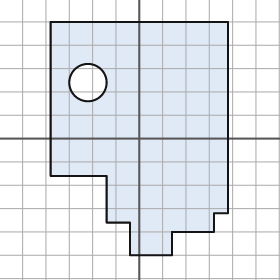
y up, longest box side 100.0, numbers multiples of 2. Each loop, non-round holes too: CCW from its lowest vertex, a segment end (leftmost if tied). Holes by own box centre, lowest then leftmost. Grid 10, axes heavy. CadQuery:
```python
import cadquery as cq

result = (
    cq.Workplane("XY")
    .moveTo(-4.0, -50.0)
    .lineTo(14.0, -50.0)
    .lineTo(14.0, -40.0)
    .lineTo(32.0, -40.0)
    .lineTo(32.0, -32.0)
    .lineTo(38.0, -32.0)
    .lineTo(38.0, 50.0)
    .lineTo(-38.0, 50.0)
    .lineTo(-38.0, -16.0)
    .lineTo(-14.0, -16.0)
    .lineTo(-14.0, -36.0)
    .lineTo(-4.0, -36.0)
    .close()
    .moveTo(-22.0, 24.0)
    .circle(8.0)
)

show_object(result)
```